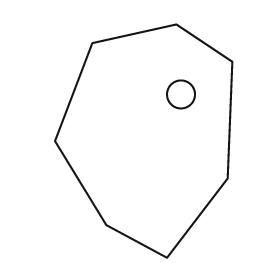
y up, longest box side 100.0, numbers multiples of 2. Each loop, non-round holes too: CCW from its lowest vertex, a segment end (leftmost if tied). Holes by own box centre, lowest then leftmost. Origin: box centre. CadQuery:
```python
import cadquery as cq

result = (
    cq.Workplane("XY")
    .moveTo(10.0, -50.0)
    .lineTo(36.0, -16.0)
    .lineTo(38.0, 34.0)
    .lineTo(14.0, 50.0)
    .lineTo(-22.0, 42.0)
    .lineTo(-38.0, 0.0)
    .lineTo(-16.0, -36.0)
    .close()
    .moveTo(16.0, 20.0)
    .circle(6.0)
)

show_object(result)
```